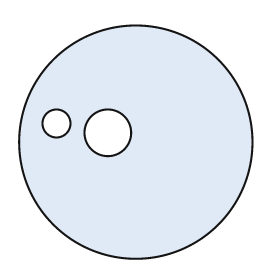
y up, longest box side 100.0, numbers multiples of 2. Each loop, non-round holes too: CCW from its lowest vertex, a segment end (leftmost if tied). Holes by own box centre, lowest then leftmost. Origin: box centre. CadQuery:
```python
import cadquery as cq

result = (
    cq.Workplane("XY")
    .moveTo(0.0, 0.0)
    .circle(50.0)
    .moveTo(-12.0, 4.0)
    .circle(10.0)
    .moveTo(-34.0, 8.0)
    .circle(6.0)
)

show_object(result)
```